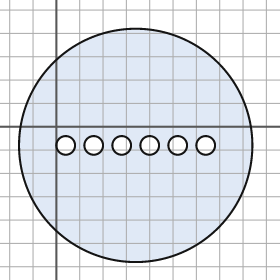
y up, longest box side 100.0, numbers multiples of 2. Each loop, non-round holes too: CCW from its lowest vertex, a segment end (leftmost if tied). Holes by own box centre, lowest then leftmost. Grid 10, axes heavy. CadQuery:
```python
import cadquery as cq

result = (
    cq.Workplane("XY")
    .moveTo(34.0, -8.0)
    .circle(50.0)
    .moveTo(4.0, -8.0)
    .circle(4.0)
    .moveTo(16.0, -8.0)
    .circle(4.0)
    .moveTo(28.0, -8.0)
    .circle(4.0)
    .moveTo(40.0, -8.0)
    .circle(4.0)
    .moveTo(52.0, -8.0)
    .circle(4.0)
    .moveTo(64.0, -8.0)
    .circle(4.0)
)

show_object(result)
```